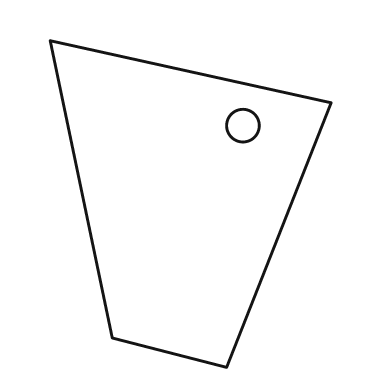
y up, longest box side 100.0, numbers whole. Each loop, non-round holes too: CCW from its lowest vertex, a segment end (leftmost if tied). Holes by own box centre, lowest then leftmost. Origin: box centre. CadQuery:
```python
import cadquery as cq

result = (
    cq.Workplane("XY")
    .moveTo(11.0, -50.0)
    .lineTo(43.0, 31.0)
    .lineTo(-43.0, 50.0)
    .lineTo(-24.0, -41.0)
    .close()
    .moveTo(16.0, 24.0)
    .circle(5.0)
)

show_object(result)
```